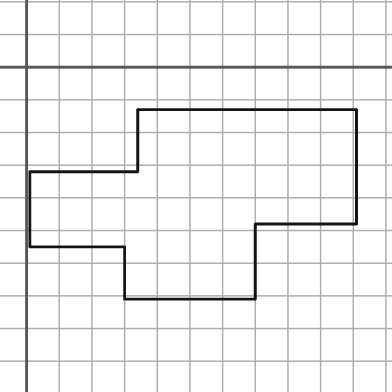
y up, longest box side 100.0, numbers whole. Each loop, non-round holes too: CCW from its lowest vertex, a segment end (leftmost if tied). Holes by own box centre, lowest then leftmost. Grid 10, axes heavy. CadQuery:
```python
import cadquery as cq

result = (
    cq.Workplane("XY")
    .moveTo(30.0, -71.0)
    .lineTo(70.0, -71.0)
    .lineTo(70.0, -48.0)
    .lineTo(101.0, -48.0)
    .lineTo(101.0, -13.0)
    .lineTo(34.0, -13.0)
    .lineTo(34.0, -32.0)
    .lineTo(1.0, -32.0)
    .lineTo(1.0, -55.0)
    .lineTo(30.0, -55.0)
    .close()
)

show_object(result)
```